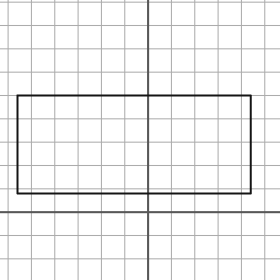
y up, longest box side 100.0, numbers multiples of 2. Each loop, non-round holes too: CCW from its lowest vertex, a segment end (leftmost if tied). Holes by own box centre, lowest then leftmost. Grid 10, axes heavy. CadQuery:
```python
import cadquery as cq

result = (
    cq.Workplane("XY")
    .moveTo(-56.0, 8.0)
    .lineTo(44.0, 8.0)
    .lineTo(44.0, 50.0)
    .lineTo(-56.0, 50.0)
    .close()
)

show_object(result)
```